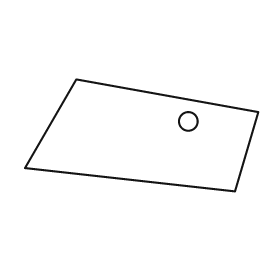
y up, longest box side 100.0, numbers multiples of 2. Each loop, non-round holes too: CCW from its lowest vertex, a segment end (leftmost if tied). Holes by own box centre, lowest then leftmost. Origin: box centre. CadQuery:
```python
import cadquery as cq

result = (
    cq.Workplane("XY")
    .moveTo(40.0, -24.0)
    .lineTo(50.0, 10.0)
    .lineTo(-28.0, 24.0)
    .lineTo(-50.0, -14.0)
    .close()
    .moveTo(20.0, 6.0)
    .circle(4.0)
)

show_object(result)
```